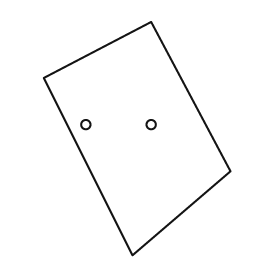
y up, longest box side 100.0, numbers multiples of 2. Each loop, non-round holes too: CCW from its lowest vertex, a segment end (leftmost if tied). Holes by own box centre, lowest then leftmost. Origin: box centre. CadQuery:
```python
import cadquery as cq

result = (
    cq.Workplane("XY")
    .moveTo(-2.0, -50.0)
    .lineTo(40.0, -14.0)
    .lineTo(6.0, 50.0)
    .lineTo(-40.0, 26.0)
    .close()
    .moveTo(-22.0, 6.0)
    .circle(2.0)
    .moveTo(6.0, 6.0)
    .circle(2.0)
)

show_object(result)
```